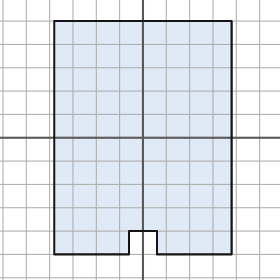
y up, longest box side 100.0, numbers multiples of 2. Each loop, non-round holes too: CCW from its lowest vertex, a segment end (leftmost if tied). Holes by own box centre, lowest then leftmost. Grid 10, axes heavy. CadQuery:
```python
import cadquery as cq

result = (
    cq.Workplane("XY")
    .moveTo(-38.0, -50.0)
    .lineTo(-6.0, -50.0)
    .lineTo(-6.0, -40.0)
    .lineTo(6.0, -40.0)
    .lineTo(6.0, -50.0)
    .lineTo(38.0, -50.0)
    .lineTo(38.0, 50.0)
    .lineTo(-38.0, 50.0)
    .close()
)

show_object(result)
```